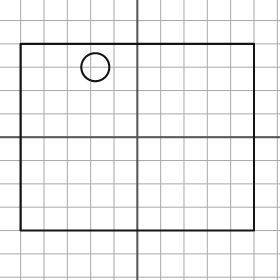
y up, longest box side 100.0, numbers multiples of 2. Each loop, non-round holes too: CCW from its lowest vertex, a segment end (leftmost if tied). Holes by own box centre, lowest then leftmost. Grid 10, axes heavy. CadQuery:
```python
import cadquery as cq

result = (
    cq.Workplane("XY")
    .moveTo(-50.0, -40.0)
    .lineTo(50.0, -40.0)
    .lineTo(50.0, 40.0)
    .lineTo(-50.0, 40.0)
    .close()
    .moveTo(-18.0, 30.0)
    .circle(6.0)
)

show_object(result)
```